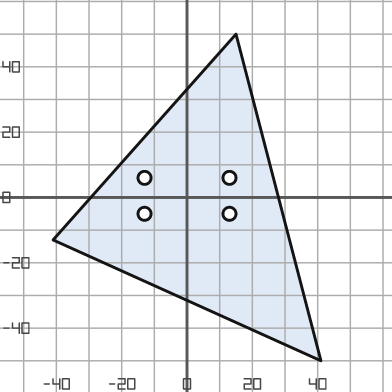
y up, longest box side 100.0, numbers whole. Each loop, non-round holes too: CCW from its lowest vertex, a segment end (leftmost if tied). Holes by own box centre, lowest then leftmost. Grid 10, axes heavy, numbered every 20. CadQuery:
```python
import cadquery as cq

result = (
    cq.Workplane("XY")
    .moveTo(41.0, -50.0)
    .lineTo(15.0, 50.0)
    .lineTo(-41.0, -13.0)
    .close()
    .moveTo(-13.0, -5.0)
    .circle(2.0)
    .moveTo(13.0, -5.0)
    .circle(2.0)
    .moveTo(-13.0, 6.0)
    .circle(2.0)
    .moveTo(13.0, 6.0)
    .circle(2.0)
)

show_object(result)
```